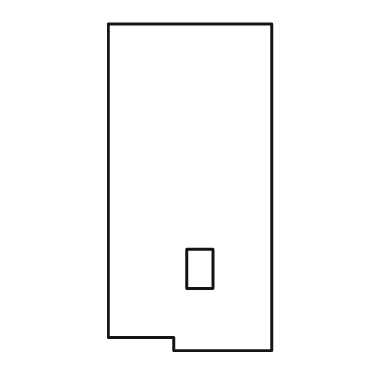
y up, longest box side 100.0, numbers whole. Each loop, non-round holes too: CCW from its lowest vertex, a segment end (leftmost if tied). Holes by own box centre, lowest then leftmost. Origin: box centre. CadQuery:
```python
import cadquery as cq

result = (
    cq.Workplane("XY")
    .moveTo(-5.0, -50.0)
    .lineTo(25.0, -50.0)
    .lineTo(25.0, 50.0)
    .lineTo(-25.0, 50.0)
    .lineTo(-25.0, -46.0)
    .lineTo(-5.0, -46.0)
    .close()
    .moveTo(-1.0, -31.0)
    .lineTo(7.0, -31.0)
    .lineTo(7.0, -19.0)
    .lineTo(-1.0, -19.0)
    .close()
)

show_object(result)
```